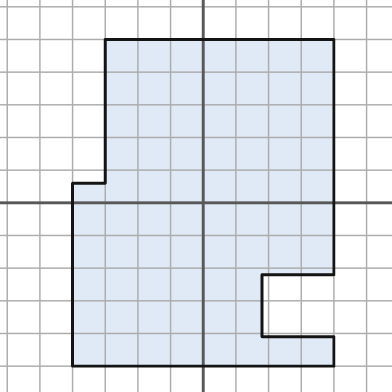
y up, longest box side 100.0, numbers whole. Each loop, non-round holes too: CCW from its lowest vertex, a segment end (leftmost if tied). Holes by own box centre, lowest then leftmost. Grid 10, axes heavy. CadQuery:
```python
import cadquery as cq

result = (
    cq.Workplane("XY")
    .moveTo(-40.0, -50.0)
    .lineTo(40.0, -50.0)
    .lineTo(40.0, -41.0)
    .lineTo(18.0, -41.0)
    .lineTo(18.0, -22.0)
    .lineTo(40.0, -22.0)
    .lineTo(40.0, 50.0)
    .lineTo(-30.0, 50.0)
    .lineTo(-30.0, 6.0)
    .lineTo(-40.0, 6.0)
    .close()
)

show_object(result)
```